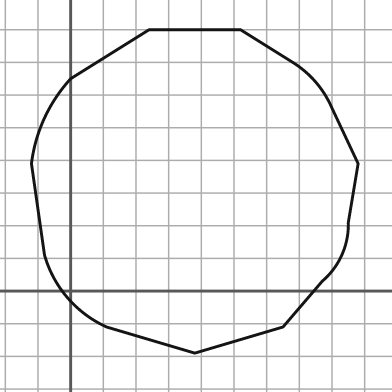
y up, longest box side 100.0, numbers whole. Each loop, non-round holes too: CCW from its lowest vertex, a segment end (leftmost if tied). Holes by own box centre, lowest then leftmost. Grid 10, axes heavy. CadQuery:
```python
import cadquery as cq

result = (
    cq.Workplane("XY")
    .moveTo(38.0, -19.0)
    .lineTo(65.0, -11.0)
    .lineTo(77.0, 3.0)
    .threePointArc((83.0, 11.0), (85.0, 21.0))
    .lineTo(88.0, 39.0)
    .lineTo(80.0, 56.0)
    .threePointArc((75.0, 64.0), (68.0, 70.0))
    .lineTo(52.0, 80.0)
    .lineTo(24.0, 80.0)
    .lineTo(0.0, 65.0)
    .threePointArc((-8.0, 53.0), (-12.0, 39.0))
    .lineTo(-8.0, 11.0)
    .threePointArc((-1.0, -2.0), (11.0, -11.0))
    .close()
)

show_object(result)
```